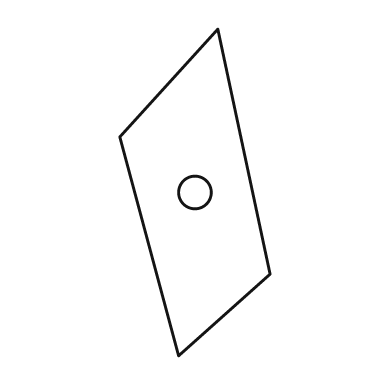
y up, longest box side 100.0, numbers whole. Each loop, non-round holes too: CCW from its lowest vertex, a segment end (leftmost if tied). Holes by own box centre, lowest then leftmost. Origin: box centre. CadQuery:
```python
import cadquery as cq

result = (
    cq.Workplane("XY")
    .moveTo(-5.0, -50.0)
    .lineTo(23.0, -25.0)
    .lineTo(7.0, 50.0)
    .lineTo(-23.0, 17.0)
    .close()
    .moveTo(0.0, 0.0)
    .circle(5.0)
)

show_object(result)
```